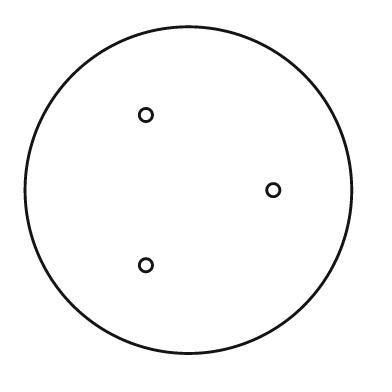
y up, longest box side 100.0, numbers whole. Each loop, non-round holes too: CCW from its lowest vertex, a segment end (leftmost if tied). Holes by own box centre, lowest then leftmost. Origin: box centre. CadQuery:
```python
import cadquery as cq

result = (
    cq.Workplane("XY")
    .moveTo(0.0, 0.0)
    .circle(50.0)
    .moveTo(-13.0, -23.0)
    .circle(2.0)
    .moveTo(26.0, 0.0)
    .circle(2.0)
    .moveTo(-13.0, 23.0)
    .circle(2.0)
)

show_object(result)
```